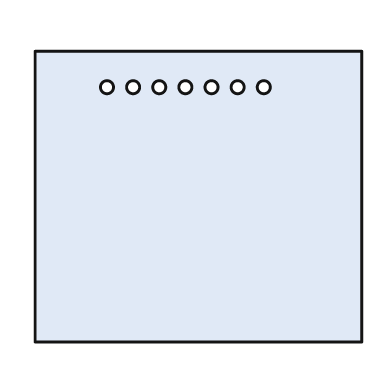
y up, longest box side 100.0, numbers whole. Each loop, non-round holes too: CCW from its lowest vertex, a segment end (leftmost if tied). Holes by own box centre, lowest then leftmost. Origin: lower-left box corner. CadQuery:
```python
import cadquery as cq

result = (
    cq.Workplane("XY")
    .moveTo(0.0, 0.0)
    .lineTo(100.0, 0.0)
    .lineTo(100.0, 89.0)
    .lineTo(0.0, 89.0)
    .close()
    .moveTo(22.0, 78.0)
    .circle(2.0)
    .moveTo(30.0, 78.0)
    .circle(2.0)
    .moveTo(38.0, 78.0)
    .circle(2.0)
    .moveTo(46.0, 78.0)
    .circle(2.0)
    .moveTo(54.0, 78.0)
    .circle(2.0)
    .moveTo(62.0, 78.0)
    .circle(2.0)
    .moveTo(70.0, 78.0)
    .circle(2.0)
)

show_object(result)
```